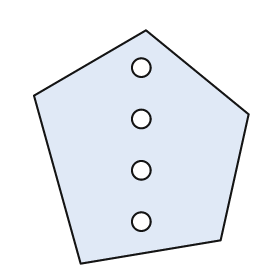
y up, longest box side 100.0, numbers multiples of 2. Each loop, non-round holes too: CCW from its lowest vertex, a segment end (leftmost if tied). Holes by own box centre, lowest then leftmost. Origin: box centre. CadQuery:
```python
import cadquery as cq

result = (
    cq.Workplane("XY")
    .moveTo(-26.0, -50.0)
    .lineTo(34.0, -40.0)
    .lineTo(46.0, 14.0)
    .lineTo(2.0, 50.0)
    .lineTo(-46.0, 22.0)
    .close()
    .moveTo(0.0, -32.0)
    .circle(4.0)
    .moveTo(0.0, -10.0)
    .circle(4.0)
    .moveTo(0.0, 12.0)
    .circle(4.0)
    .moveTo(0.0, 34.0)
    .circle(4.0)
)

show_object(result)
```